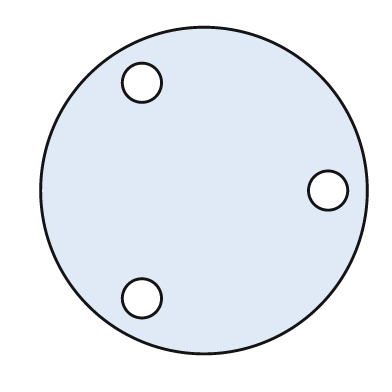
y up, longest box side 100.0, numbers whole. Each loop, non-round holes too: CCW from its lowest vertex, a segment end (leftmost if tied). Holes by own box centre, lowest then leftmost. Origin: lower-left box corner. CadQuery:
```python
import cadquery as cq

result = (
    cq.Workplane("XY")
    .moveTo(50.0, 50.0)
    .circle(50.0)
    .moveTo(31.0, 17.0)
    .circle(6.0)
    .moveTo(88.0, 50.0)
    .circle(6.0)
    .moveTo(31.0, 83.0)
    .circle(6.0)
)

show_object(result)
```